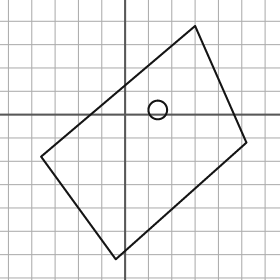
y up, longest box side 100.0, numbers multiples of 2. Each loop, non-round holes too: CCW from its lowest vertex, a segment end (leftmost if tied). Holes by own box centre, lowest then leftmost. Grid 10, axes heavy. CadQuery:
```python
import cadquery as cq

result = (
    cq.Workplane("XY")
    .moveTo(-4.0, -62.0)
    .lineTo(52.0, -12.0)
    .lineTo(30.0, 38.0)
    .lineTo(-36.0, -18.0)
    .close()
    .moveTo(14.0, 2.0)
    .circle(4.0)
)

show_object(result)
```